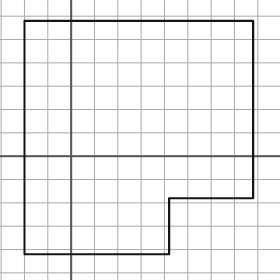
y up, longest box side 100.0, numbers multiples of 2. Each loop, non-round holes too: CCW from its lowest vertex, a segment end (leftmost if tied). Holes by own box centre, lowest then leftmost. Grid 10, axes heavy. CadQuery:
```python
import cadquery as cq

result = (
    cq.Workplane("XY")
    .moveTo(-20.0, -42.0)
    .lineTo(42.0, -42.0)
    .lineTo(42.0, -18.0)
    .lineTo(78.0, -18.0)
    .lineTo(78.0, 58.0)
    .lineTo(-20.0, 58.0)
    .close()
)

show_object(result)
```